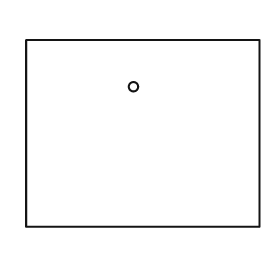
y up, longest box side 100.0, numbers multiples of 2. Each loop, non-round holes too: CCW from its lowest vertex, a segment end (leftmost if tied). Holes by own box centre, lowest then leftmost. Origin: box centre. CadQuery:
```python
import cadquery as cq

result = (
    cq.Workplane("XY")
    .moveTo(-50.0, -40.0)
    .lineTo(50.0, -40.0)
    .lineTo(50.0, 40.0)
    .lineTo(-50.0, 40.0)
    .close()
    .moveTo(-4.0, 20.0)
    .circle(2.0)
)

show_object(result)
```